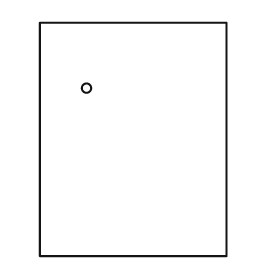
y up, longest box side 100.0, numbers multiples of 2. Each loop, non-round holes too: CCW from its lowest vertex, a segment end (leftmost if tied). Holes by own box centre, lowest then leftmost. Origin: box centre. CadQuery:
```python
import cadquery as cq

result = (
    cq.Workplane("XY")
    .moveTo(-40.0, -50.0)
    .lineTo(40.0, -50.0)
    .lineTo(40.0, 50.0)
    .lineTo(-40.0, 50.0)
    .close()
    .moveTo(-20.0, 22.0)
    .circle(2.0)
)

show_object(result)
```